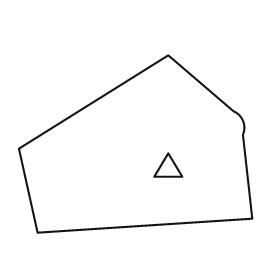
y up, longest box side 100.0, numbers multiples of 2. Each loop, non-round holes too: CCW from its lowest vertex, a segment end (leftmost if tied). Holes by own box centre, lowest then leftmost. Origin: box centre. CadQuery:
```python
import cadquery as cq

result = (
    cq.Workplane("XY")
    .moveTo(-42.0, -38.0)
    .lineTo(50.0, -32.0)
    .lineTo(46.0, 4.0)
    .threePointArc((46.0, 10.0), (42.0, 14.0))
    .lineTo(14.0, 38.0)
    .lineTo(-50.0, -2.0)
    .close()
    .moveTo(8.0, -14.0)
    .lineTo(20.0, -14.0)
    .lineTo(14.0, -4.0)
    .close()
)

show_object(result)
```